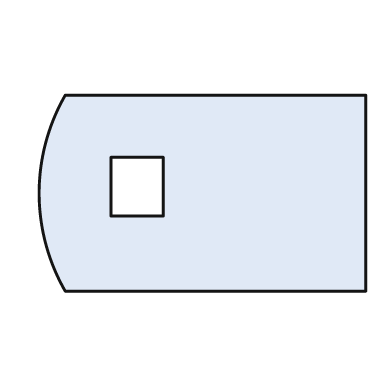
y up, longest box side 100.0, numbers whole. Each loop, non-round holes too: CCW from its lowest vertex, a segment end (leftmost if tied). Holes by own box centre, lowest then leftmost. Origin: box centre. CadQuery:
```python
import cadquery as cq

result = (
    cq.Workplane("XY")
    .moveTo(-42.0, -30.0)
    .lineTo(50.0, -30.0)
    .lineTo(50.0, 30.0)
    .lineTo(-42.0, 30.0)
    .threePointArc((-50.0, 0.0), (-42.0, -30.0))
    .close()
    .moveTo(-28.0, -7.0)
    .lineTo(-12.0, -7.0)
    .lineTo(-12.0, 11.0)
    .lineTo(-28.0, 11.0)
    .close()
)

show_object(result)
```